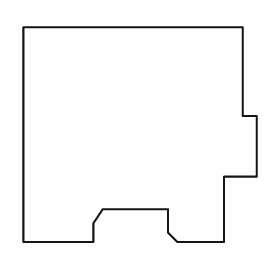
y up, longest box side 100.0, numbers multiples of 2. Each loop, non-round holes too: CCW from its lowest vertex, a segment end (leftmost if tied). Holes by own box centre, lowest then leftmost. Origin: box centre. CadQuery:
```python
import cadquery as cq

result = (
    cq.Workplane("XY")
    .moveTo(-50.0, -46.0)
    .lineTo(-20.0, -46.0)
    .lineTo(-20.0, -38.0)
    .lineTo(-16.0, -32.0)
    .lineTo(12.0, -32.0)
    .lineTo(12.0, -42.0)
    .lineTo(16.0, -46.0)
    .lineTo(36.0, -46.0)
    .lineTo(36.0, -18.0)
    .lineTo(50.0, -18.0)
    .lineTo(50.0, 8.0)
    .lineTo(44.0, 8.0)
    .lineTo(44.0, 46.0)
    .lineTo(-50.0, 46.0)
    .close()
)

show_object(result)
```